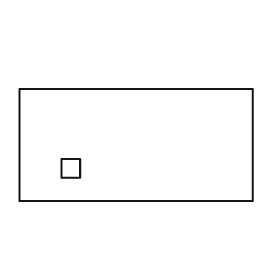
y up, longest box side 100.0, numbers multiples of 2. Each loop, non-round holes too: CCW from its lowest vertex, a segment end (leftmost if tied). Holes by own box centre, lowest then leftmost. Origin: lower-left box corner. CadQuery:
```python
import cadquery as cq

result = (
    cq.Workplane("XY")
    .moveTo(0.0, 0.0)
    .lineTo(100.0, 0.0)
    .lineTo(100.0, 48.0)
    .lineTo(0.0, 48.0)
    .close()
    .moveTo(18.0, 10.0)
    .lineTo(26.0, 10.0)
    .lineTo(26.0, 18.0)
    .lineTo(18.0, 18.0)
    .close()
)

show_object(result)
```